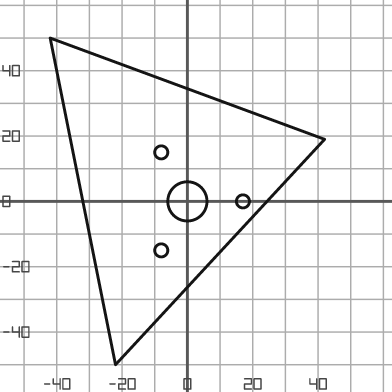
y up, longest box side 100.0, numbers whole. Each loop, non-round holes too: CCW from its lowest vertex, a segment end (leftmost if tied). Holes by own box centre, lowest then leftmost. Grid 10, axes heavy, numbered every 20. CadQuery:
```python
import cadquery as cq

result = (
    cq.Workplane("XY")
    .moveTo(-22.0, -50.0)
    .lineTo(42.0, 19.0)
    .lineTo(-42.0, 50.0)
    .close()
    .moveTo(-8.0, -15.0)
    .circle(2.0)
    .moveTo(0.0, 0.0)
    .circle(6.0)
    .moveTo(17.0, 0.0)
    .circle(2.0)
    .moveTo(-8.0, 15.0)
    .circle(2.0)
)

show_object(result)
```